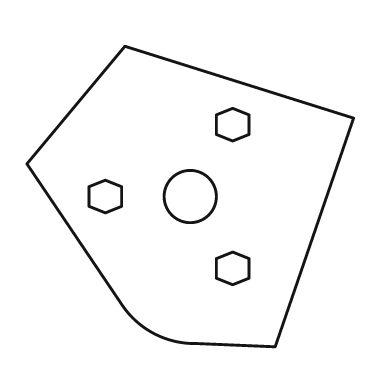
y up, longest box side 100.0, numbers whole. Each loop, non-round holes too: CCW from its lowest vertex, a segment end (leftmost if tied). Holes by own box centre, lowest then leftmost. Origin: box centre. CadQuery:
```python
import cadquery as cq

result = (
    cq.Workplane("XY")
    .moveTo(26.0, -46.0)
    .lineTo(50.0, 24.0)
    .lineTo(-20.0, 46.0)
    .lineTo(-50.0, 10.0)
    .lineTo(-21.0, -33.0)
    .threePointArc((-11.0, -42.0), (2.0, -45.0))
    .close()
    .moveTo(13.0, -27.0)
    .lineTo(18.0, -25.0)
    .lineTo(18.0, -19.0)
    .lineTo(13.0, -17.0)
    .lineTo(8.0, -19.0)
    .lineTo(8.0, -25.0)
    .close()
    .moveTo(-26.0, -5.0)
    .lineTo(-21.0, -3.0)
    .lineTo(-21.0, 3.0)
    .lineTo(-26.0, 5.0)
    .lineTo(-31.0, 3.0)
    .lineTo(-31.0, -3.0)
    .close()
    .moveTo(0.0, 0.0)
    .circle(8.0)
    .moveTo(13.0, 17.0)
    .lineTo(18.0, 19.0)
    .lineTo(18.0, 25.0)
    .lineTo(13.0, 27.0)
    .lineTo(8.0, 25.0)
    .lineTo(8.0, 19.0)
    .close()
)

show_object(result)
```